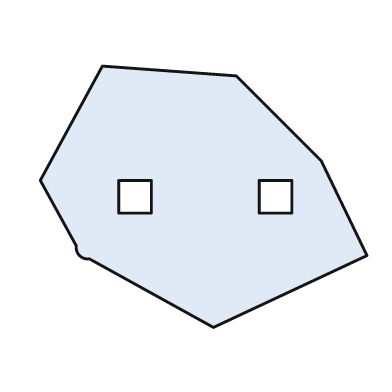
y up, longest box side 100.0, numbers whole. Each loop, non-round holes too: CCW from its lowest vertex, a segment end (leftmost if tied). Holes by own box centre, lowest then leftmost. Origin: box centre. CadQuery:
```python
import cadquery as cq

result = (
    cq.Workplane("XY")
    .moveTo(3.0, -40.0)
    .lineTo(50.0, -18.0)
    .lineTo(36.0, 11.0)
    .lineTo(10.0, 37.0)
    .lineTo(-31.0, 40.0)
    .lineTo(-50.0, 5.0)
    .lineTo(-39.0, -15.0)
    .threePointArc((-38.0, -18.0), (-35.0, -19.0))
    .close()
    .moveTo(-26.0, -5.0)
    .lineTo(-16.0, -5.0)
    .lineTo(-16.0, 5.0)
    .lineTo(-26.0, 5.0)
    .close()
    .moveTo(17.0, -5.0)
    .lineTo(27.0, -5.0)
    .lineTo(27.0, 5.0)
    .lineTo(17.0, 5.0)
    .close()
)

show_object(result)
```